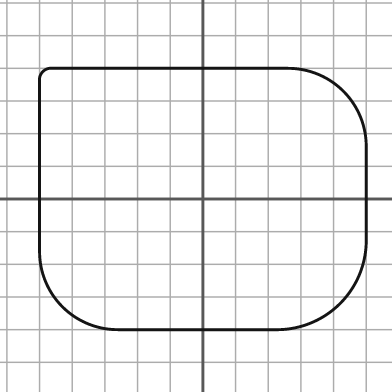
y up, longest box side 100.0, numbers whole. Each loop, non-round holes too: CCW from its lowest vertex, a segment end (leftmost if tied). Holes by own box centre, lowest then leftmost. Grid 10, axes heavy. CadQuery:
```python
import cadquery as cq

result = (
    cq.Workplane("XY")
    .moveTo(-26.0, -40.0)
    .lineTo(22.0, -40.0)
    .threePointArc((42.0, -32.0), (50.0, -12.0))
    .lineTo(50.0, 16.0)
    .threePointArc((43.0, 33.0), (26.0, 40.0))
    .lineTo(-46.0, 40.0)
    .threePointArc((-49.0, 39.0), (-50.0, 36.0))
    .lineTo(-50.0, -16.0)
    .threePointArc((-43.0, -33.0), (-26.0, -40.0))
    .close()
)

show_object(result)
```